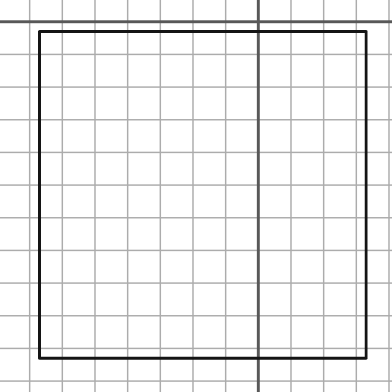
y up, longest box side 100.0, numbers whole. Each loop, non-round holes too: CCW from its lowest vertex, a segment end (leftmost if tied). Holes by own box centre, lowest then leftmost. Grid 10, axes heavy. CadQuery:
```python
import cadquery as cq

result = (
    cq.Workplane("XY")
    .moveTo(-67.0, -103.0)
    .lineTo(33.0, -103.0)
    .lineTo(33.0, -3.0)
    .lineTo(-67.0, -3.0)
    .close()
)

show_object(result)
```